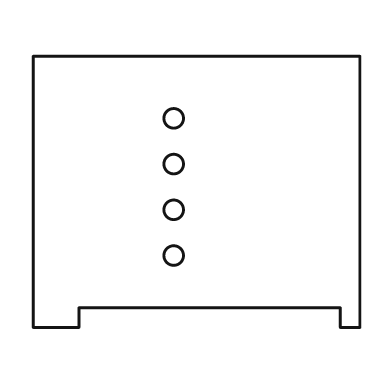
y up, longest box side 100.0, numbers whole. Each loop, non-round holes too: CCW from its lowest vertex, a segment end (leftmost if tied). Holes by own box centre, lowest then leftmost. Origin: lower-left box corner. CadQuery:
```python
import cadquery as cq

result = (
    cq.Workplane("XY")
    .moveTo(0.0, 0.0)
    .lineTo(14.0, 0.0)
    .lineTo(14.0, 6.0)
    .lineTo(94.0, 6.0)
    .lineTo(94.0, 0.0)
    .lineTo(100.0, 0.0)
    .lineTo(100.0, 83.0)
    .lineTo(0.0, 83.0)
    .close()
    .moveTo(43.0, 22.0)
    .circle(3.0)
    .moveTo(43.0, 36.0)
    .circle(3.0)
    .moveTo(43.0, 50.0)
    .circle(3.0)
    .moveTo(43.0, 64.0)
    .circle(3.0)
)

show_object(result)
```